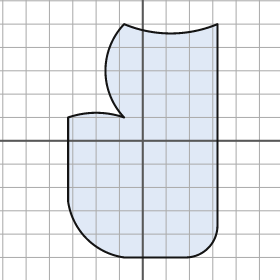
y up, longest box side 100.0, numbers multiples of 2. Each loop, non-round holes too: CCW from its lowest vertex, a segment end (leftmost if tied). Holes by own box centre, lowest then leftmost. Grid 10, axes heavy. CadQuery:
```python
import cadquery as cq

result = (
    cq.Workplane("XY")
    .moveTo(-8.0, -50.0)
    .lineTo(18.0, -50.0)
    .threePointArc((28.0, -46.0), (32.0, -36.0))
    .lineTo(32.0, 50.0)
    .threePointArc((12.0, 46.0), (-8.0, 50.0))
    .threePointArc((-16.0, 30.0), (-8.0, 10.0))
    .threePointArc((-20.0, 12.0), (-32.0, 10.0))
    .lineTo(-32.0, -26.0)
    .threePointArc((-24.0, -42.0), (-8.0, -50.0))
    .close()
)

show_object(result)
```